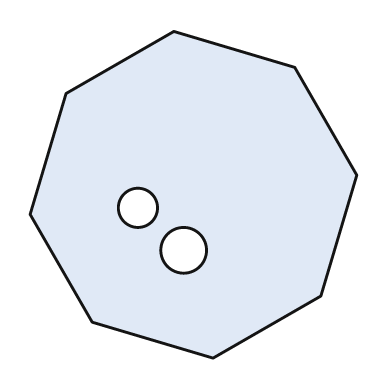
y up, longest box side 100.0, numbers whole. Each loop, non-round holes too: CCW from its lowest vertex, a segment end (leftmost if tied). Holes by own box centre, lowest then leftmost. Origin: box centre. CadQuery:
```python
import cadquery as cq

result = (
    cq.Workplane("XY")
    .moveTo(6.0, -50.0)
    .lineTo(39.0, -31.0)
    .lineTo(50.0, 6.0)
    .lineTo(31.0, 39.0)
    .lineTo(-6.0, 50.0)
    .lineTo(-39.0, 31.0)
    .lineTo(-50.0, -6.0)
    .lineTo(-31.0, -39.0)
    .close()
    .moveTo(-3.0, -17.0)
    .circle(7.0)
    .moveTo(-17.0, -4.0)
    .circle(6.0)
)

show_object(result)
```